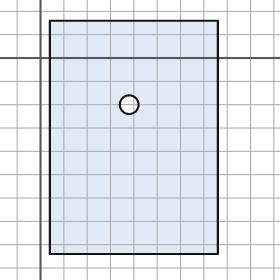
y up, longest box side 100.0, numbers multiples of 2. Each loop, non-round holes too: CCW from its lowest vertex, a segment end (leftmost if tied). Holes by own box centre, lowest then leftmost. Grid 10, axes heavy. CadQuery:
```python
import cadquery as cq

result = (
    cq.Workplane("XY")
    .moveTo(4.0, -84.0)
    .lineTo(76.0, -84.0)
    .lineTo(76.0, 16.0)
    .lineTo(4.0, 16.0)
    .close()
    .moveTo(38.0, -20.0)
    .circle(4.0)
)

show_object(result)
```